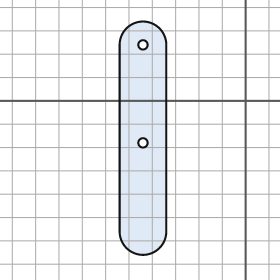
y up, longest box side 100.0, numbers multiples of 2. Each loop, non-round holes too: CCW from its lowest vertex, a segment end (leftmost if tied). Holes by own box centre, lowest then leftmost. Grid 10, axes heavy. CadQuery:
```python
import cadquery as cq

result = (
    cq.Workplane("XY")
    .moveTo(-54.0, -56.0)
    .threePointArc((-44.0, -66.0), (-34.0, -56.0))
    .lineTo(-34.0, 24.0)
    .threePointArc((-44.0, 34.0), (-54.0, 24.0))
    .close()
    .moveTo(-44.0, -18.0)
    .circle(2.0)
    .moveTo(-44.0, 24.0)
    .circle(2.0)
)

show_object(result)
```